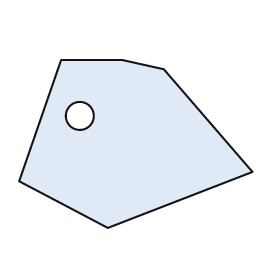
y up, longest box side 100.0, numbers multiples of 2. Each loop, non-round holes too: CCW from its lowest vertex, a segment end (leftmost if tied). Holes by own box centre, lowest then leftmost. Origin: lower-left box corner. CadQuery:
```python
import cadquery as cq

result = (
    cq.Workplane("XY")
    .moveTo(38.0, 0.0)
    .lineTo(100.0, 24.0)
    .lineTo(62.0, 68.0)
    .lineTo(44.0, 72.0)
    .lineTo(18.0, 72.0)
    .lineTo(0.0, 20.0)
    .close()
    .moveTo(26.0, 48.0)
    .circle(6.0)
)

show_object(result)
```